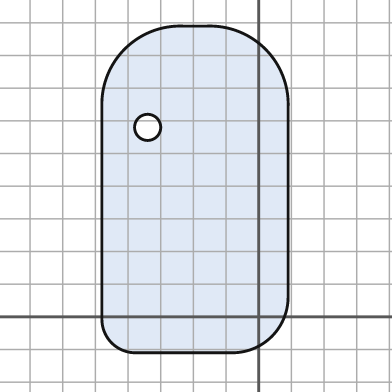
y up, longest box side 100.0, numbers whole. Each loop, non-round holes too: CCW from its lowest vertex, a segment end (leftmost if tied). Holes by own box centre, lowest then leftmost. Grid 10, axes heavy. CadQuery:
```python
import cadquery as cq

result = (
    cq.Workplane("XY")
    .moveTo(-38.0, -11.0)
    .lineTo(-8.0, -11.0)
    .threePointArc((4.0, -6.0), (9.0, 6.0))
    .lineTo(9.0, 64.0)
    .threePointArc((2.0, 82.0), (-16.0, 89.0))
    .lineTo(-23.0, 89.0)
    .threePointArc((-41.0, 82.0), (-48.0, 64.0))
    .lineTo(-48.0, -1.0)
    .threePointArc((-45.0, -8.0), (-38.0, -11.0))
    .close()
    .moveTo(-34.0, 58.0)
    .circle(4.0)
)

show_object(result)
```